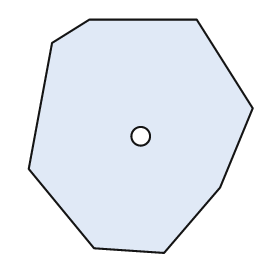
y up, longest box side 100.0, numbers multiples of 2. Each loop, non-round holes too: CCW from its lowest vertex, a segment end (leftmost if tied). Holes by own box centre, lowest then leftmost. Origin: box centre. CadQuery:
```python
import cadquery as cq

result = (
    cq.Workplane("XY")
    .moveTo(10.0, -50.0)
    .lineTo(34.0, -22.0)
    .lineTo(48.0, 12.0)
    .lineTo(24.0, 50.0)
    .lineTo(-22.0, 50.0)
    .lineTo(-38.0, 40.0)
    .lineTo(-48.0, -14.0)
    .lineTo(-20.0, -48.0)
    .close()
    .moveTo(0.0, 0.0)
    .circle(4.0)
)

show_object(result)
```